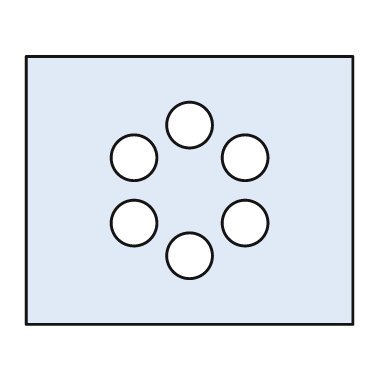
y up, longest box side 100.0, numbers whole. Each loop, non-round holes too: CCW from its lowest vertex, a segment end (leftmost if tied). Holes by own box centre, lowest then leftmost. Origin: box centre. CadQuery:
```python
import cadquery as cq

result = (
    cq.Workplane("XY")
    .moveTo(-50.0, -41.0)
    .lineTo(50.0, -41.0)
    .lineTo(50.0, 41.0)
    .lineTo(-50.0, 41.0)
    .close()
    .moveTo(0.0, -20.0)
    .circle(7.0)
    .moveTo(-17.0, -10.0)
    .circle(7.0)
    .moveTo(17.0, -10.0)
    .circle(7.0)
    .moveTo(-17.0, 10.0)
    .circle(7.0)
    .moveTo(17.0, 10.0)
    .circle(7.0)
    .moveTo(0.0, 20.0)
    .circle(7.0)
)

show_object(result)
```